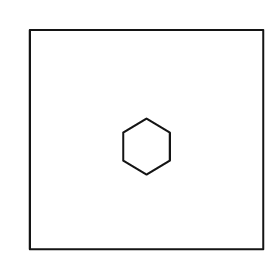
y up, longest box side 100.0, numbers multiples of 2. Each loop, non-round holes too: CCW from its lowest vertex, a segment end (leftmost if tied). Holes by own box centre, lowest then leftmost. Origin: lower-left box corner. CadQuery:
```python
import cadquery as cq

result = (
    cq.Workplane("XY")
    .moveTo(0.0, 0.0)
    .lineTo(100.0, 0.0)
    .lineTo(100.0, 94.0)
    .lineTo(0.0, 94.0)
    .close()
    .moveTo(50.0, 32.0)
    .lineTo(60.0, 38.0)
    .lineTo(60.0, 50.0)
    .lineTo(50.0, 56.0)
    .lineTo(40.0, 50.0)
    .lineTo(40.0, 38.0)
    .close()
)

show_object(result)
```